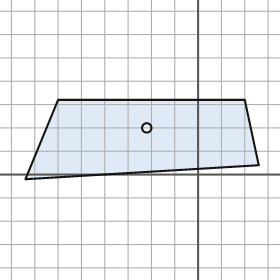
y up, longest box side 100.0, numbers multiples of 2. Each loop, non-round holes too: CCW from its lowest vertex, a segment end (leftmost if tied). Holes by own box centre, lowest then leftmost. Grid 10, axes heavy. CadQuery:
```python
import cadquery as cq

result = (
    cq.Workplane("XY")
    .moveTo(-74.0, -2.0)
    .lineTo(26.0, 4.0)
    .lineTo(20.0, 32.0)
    .lineTo(-60.0, 32.0)
    .close()
    .moveTo(-22.0, 20.0)
    .circle(2.0)
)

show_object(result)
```